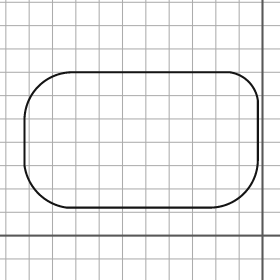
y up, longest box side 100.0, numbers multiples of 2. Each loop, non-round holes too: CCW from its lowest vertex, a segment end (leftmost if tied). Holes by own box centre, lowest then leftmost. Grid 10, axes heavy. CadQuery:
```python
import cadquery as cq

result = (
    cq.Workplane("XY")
    .moveTo(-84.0, 12.0)
    .lineTo(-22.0, 12.0)
    .threePointArc((-8.0, 18.0), (-2.0, 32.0))
    .lineTo(-2.0, 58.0)
    .threePointArc((-6.0, 66.0), (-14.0, 70.0))
    .lineTo(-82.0, 70.0)
    .threePointArc((-96.0, 64.0), (-102.0, 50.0))
    .lineTo(-102.0, 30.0)
    .threePointArc((-96.0, 18.0), (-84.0, 12.0))
    .close()
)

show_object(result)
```